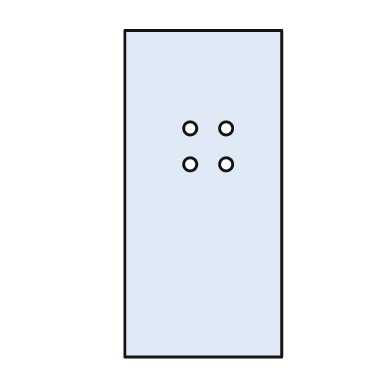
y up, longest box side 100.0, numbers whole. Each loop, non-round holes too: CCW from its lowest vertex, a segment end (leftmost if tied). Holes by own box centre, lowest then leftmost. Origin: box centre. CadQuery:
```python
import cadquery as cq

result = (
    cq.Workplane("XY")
    .moveTo(-24.0, -50.0)
    .lineTo(24.0, -50.0)
    .lineTo(24.0, 50.0)
    .lineTo(-24.0, 50.0)
    .close()
    .moveTo(-4.0, 9.0)
    .circle(2.0)
    .moveTo(7.0, 9.0)
    .circle(2.0)
    .moveTo(-4.0, 20.0)
    .circle(2.0)
    .moveTo(7.0, 20.0)
    .circle(2.0)
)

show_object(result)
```